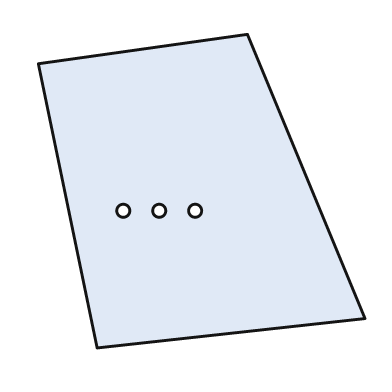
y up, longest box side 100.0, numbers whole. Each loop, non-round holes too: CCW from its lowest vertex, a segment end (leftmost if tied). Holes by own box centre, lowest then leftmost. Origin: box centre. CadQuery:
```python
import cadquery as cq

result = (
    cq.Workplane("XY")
    .moveTo(-32.0, -48.0)
    .lineTo(50.0, -39.0)
    .lineTo(14.0, 48.0)
    .lineTo(-50.0, 39.0)
    .close()
    .moveTo(-24.0, -6.0)
    .circle(2.0)
    .moveTo(-13.0, -6.0)
    .circle(2.0)
    .moveTo(-2.0, -6.0)
    .circle(2.0)
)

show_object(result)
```